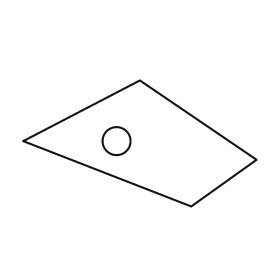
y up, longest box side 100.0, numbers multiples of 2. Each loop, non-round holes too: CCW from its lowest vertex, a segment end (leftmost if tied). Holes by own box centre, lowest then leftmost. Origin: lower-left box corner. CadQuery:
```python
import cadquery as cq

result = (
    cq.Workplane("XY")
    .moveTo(72.0, 0.0)
    .lineTo(100.0, 20.0)
    .lineTo(50.0, 54.0)
    .lineTo(0.0, 28.0)
    .close()
    .moveTo(40.0, 28.0)
    .circle(6.0)
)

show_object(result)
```